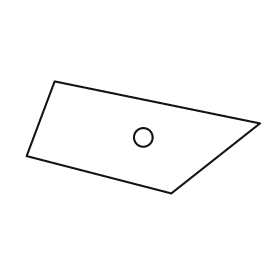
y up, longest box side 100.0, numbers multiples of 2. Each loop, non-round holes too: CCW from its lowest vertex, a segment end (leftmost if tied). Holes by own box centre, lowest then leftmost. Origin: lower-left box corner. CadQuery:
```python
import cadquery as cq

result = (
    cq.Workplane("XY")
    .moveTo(62.0, 0.0)
    .lineTo(100.0, 30.0)
    .lineTo(12.0, 48.0)
    .lineTo(0.0, 16.0)
    .close()
    .moveTo(50.0, 24.0)
    .circle(4.0)
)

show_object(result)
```